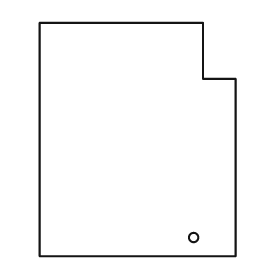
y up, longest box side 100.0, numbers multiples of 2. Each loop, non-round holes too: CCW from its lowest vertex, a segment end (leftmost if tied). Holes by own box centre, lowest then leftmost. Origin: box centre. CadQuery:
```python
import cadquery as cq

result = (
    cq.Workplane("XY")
    .moveTo(-42.0, -50.0)
    .lineTo(42.0, -50.0)
    .lineTo(42.0, 26.0)
    .lineTo(28.0, 26.0)
    .lineTo(28.0, 50.0)
    .lineTo(-42.0, 50.0)
    .close()
    .moveTo(24.0, -42.0)
    .circle(2.0)
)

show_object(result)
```